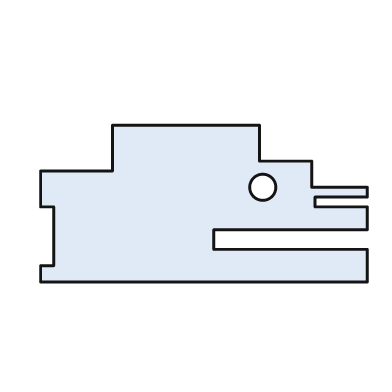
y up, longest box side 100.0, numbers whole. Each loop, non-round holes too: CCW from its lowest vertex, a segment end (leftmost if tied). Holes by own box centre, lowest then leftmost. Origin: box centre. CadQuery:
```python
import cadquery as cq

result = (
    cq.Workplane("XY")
    .moveTo(-50.0, -24.0)
    .lineTo(50.0, -24.0)
    .lineTo(50.0, -14.0)
    .lineTo(3.0, -14.0)
    .lineTo(3.0, -8.0)
    .lineTo(50.0, -8.0)
    .lineTo(50.0, -1.0)
    .lineTo(34.0, -1.0)
    .lineTo(34.0, 2.0)
    .lineTo(50.0, 2.0)
    .lineTo(50.0, 5.0)
    .lineTo(33.0, 5.0)
    .lineTo(33.0, 13.0)
    .lineTo(17.0, 13.0)
    .lineTo(17.0, 24.0)
    .lineTo(-28.0, 24.0)
    .lineTo(-28.0, 10.0)
    .lineTo(-50.0, 10.0)
    .lineTo(-50.0, -1.0)
    .lineTo(-46.0, -1.0)
    .lineTo(-46.0, -19.0)
    .lineTo(-50.0, -19.0)
    .close()
    .moveTo(18.0, 5.0)
    .circle(4.0)
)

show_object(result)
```